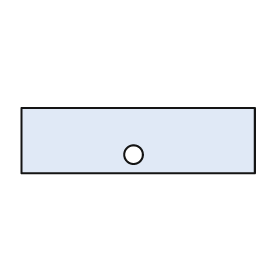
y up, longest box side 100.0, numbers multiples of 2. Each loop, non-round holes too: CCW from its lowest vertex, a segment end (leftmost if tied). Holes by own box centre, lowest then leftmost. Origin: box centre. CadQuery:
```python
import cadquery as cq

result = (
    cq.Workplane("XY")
    .moveTo(-50.0, -14.0)
    .lineTo(50.0, -14.0)
    .lineTo(50.0, 14.0)
    .lineTo(-50.0, 14.0)
    .close()
    .moveTo(-2.0, -6.0)
    .circle(4.0)
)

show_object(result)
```